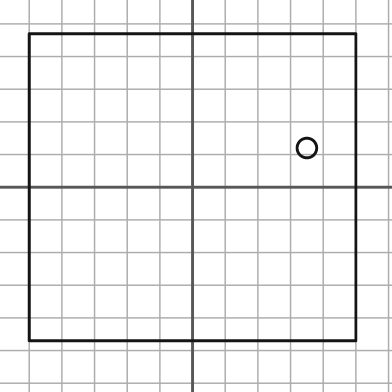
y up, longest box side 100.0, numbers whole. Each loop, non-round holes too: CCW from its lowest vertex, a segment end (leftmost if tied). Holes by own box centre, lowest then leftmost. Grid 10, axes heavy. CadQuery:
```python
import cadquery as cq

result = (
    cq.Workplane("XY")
    .moveTo(-50.0, -47.0)
    .lineTo(50.0, -47.0)
    .lineTo(50.0, 47.0)
    .lineTo(-50.0, 47.0)
    .close()
    .moveTo(35.0, 12.0)
    .circle(3.0)
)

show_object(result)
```